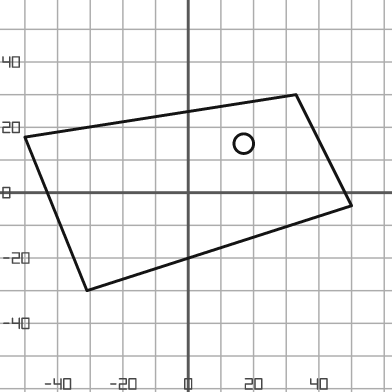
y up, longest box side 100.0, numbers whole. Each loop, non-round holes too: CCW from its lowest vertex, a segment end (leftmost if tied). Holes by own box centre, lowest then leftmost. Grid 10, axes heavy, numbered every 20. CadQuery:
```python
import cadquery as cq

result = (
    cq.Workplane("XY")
    .moveTo(-31.0, -30.0)
    .lineTo(50.0, -4.0)
    .lineTo(33.0, 30.0)
    .lineTo(-50.0, 17.0)
    .close()
    .moveTo(17.0, 15.0)
    .circle(3.0)
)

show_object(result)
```